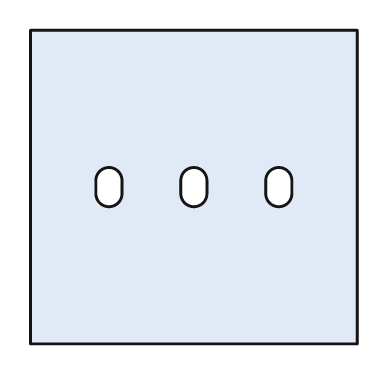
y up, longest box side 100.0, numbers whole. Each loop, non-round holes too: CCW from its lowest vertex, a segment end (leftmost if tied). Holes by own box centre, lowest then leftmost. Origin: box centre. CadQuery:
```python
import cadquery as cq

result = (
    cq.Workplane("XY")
    .moveTo(-50.0, -48.0)
    .lineTo(50.0, -48.0)
    .lineTo(50.0, 48.0)
    .lineTo(-50.0, 48.0)
    .close()
    .moveTo(-30.0, -2.0)
    .threePointArc((-26.0, -6.0), (-22.0, -2.0))
    .lineTo(-22.0, 2.0)
    .threePointArc((-26.0, 6.0), (-30.0, 2.0))
    .close()
    .moveTo(-4.0, -2.0)
    .threePointArc((0.0, -6.0), (4.0, -2.0))
    .lineTo(4.0, 2.0)
    .threePointArc((0.0, 6.0), (-4.0, 2.0))
    .close()
    .moveTo(22.0, -2.0)
    .threePointArc((26.0, -6.0), (30.0, -2.0))
    .lineTo(30.0, 2.0)
    .threePointArc((26.0, 6.0), (22.0, 2.0))
    .close()
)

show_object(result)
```